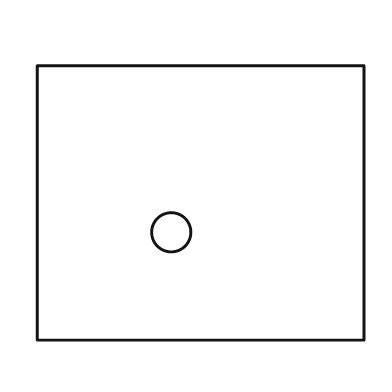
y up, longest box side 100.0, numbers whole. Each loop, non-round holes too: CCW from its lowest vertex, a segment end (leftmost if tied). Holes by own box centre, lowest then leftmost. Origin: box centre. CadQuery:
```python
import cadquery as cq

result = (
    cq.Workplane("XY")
    .moveTo(-50.0, -42.0)
    .lineTo(50.0, -42.0)
    .lineTo(50.0, 42.0)
    .lineTo(-50.0, 42.0)
    .close()
    .moveTo(-9.0, -9.0)
    .circle(6.0)
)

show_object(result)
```